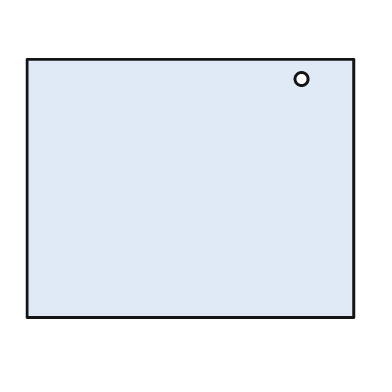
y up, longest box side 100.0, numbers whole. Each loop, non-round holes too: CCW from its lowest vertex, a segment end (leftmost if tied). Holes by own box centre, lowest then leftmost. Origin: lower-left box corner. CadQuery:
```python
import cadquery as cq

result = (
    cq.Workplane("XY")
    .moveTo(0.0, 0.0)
    .lineTo(100.0, 0.0)
    .lineTo(100.0, 79.0)
    .lineTo(0.0, 79.0)
    .close()
    .moveTo(84.0, 73.0)
    .circle(2.0)
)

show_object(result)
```